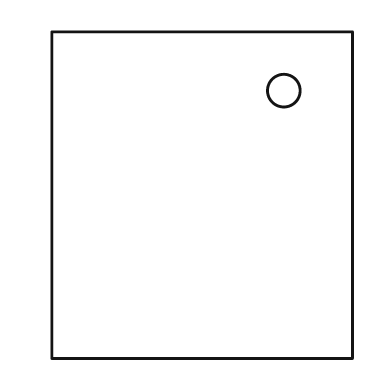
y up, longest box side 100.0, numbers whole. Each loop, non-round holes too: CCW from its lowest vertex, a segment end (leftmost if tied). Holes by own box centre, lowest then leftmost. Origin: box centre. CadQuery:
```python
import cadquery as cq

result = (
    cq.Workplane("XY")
    .moveTo(-46.0, -50.0)
    .lineTo(46.0, -50.0)
    .lineTo(46.0, 50.0)
    .lineTo(-46.0, 50.0)
    .close()
    .moveTo(25.0, 32.0)
    .circle(5.0)
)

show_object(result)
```